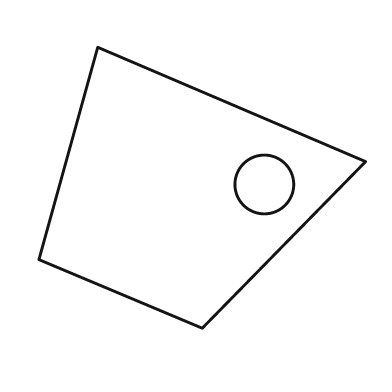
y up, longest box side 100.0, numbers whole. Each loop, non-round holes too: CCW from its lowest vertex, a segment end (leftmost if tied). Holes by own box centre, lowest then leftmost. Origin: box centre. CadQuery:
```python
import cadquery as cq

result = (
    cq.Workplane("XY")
    .moveTo(0.0, -43.0)
    .lineTo(50.0, 8.0)
    .lineTo(-32.0, 43.0)
    .lineTo(-50.0, -22.0)
    .close()
    .moveTo(19.0, 1.0)
    .circle(9.0)
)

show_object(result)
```